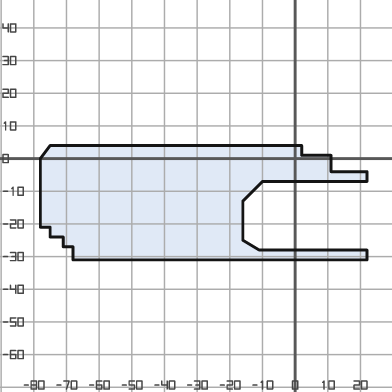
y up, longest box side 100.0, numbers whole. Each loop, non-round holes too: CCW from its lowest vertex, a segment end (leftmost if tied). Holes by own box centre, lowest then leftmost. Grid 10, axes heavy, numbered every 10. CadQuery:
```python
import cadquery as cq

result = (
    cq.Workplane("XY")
    .moveTo(-68.0, -31.0)
    .lineTo(22.0, -31.0)
    .lineTo(22.0, -28.0)
    .lineTo(-11.0, -28.0)
    .lineTo(-16.0, -25.0)
    .lineTo(-16.0, -13.0)
    .lineTo(-10.0, -7.0)
    .lineTo(22.0, -7.0)
    .lineTo(22.0, -4.0)
    .lineTo(11.0, -4.0)
    .lineTo(11.0, 1.0)
    .lineTo(2.0, 1.0)
    .lineTo(2.0, 4.0)
    .lineTo(-75.0, 4.0)
    .lineTo(-78.0, 0.0)
    .lineTo(-78.0, -21.0)
    .lineTo(-75.0, -21.0)
    .lineTo(-75.0, -24.0)
    .lineTo(-71.0, -24.0)
    .lineTo(-71.0, -27.0)
    .lineTo(-68.0, -27.0)
    .close()
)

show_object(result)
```